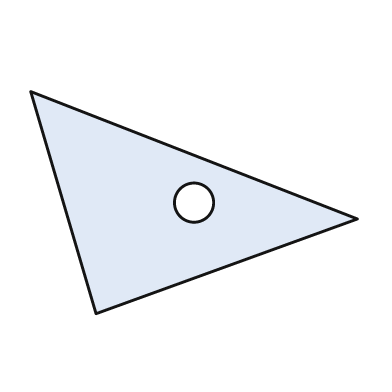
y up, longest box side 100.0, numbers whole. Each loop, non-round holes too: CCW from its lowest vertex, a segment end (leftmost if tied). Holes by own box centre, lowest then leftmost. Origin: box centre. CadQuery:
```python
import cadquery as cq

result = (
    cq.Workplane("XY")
    .moveTo(-30.0, -34.0)
    .lineTo(50.0, -5.0)
    .lineTo(-50.0, 34.0)
    .close()
    .moveTo(0.0, 0.0)
    .circle(6.0)
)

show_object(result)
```